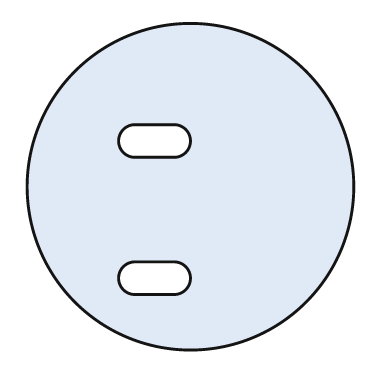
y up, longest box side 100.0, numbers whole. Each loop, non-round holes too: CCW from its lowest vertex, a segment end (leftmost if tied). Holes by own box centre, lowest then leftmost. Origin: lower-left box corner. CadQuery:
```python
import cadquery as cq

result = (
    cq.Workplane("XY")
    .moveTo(50.0, 50.0)
    .circle(50.0)
    .moveTo(33.0, 17.0)
    .lineTo(45.0, 17.0)
    .threePointArc((50.0, 22.0), (45.0, 27.0))
    .lineTo(33.0, 27.0)
    .threePointArc((28.0, 22.0), (33.0, 17.0))
    .close()
    .moveTo(33.0, 59.0)
    .lineTo(45.0, 59.0)
    .threePointArc((50.0, 64.0), (45.0, 69.0))
    .lineTo(33.0, 69.0)
    .threePointArc((28.0, 64.0), (33.0, 59.0))
    .close()
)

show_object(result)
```